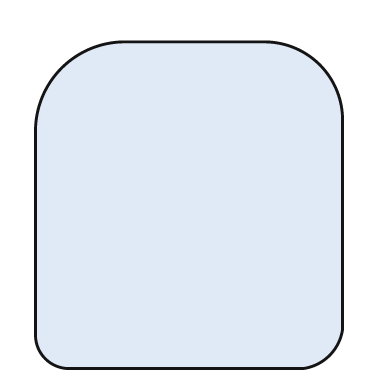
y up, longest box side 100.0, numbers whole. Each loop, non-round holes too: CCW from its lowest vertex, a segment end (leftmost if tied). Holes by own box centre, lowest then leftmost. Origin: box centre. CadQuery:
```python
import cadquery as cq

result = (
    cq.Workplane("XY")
    .moveTo(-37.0, -50.0)
    .lineTo(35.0, -50.0)
    .threePointArc((43.0, -46.0), (47.0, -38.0))
    .lineTo(47.0, 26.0)
    .threePointArc((40.0, 43.0), (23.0, 50.0))
    .lineTo(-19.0, 50.0)
    .threePointArc((-39.0, 42.0), (-47.0, 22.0))
    .lineTo(-47.0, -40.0)
    .threePointArc((-44.0, -47.0), (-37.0, -50.0))
    .close()
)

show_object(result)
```